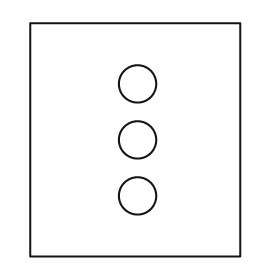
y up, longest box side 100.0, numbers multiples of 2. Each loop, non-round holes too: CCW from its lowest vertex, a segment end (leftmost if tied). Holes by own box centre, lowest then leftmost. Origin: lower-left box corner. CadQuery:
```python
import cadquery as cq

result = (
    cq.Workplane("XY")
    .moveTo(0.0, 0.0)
    .lineTo(90.0, 0.0)
    .lineTo(90.0, 100.0)
    .lineTo(0.0, 100.0)
    .close()
    .moveTo(46.0, 26.0)
    .circle(8.0)
    .moveTo(46.0, 50.0)
    .circle(8.0)
    .moveTo(46.0, 74.0)
    .circle(8.0)
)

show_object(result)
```